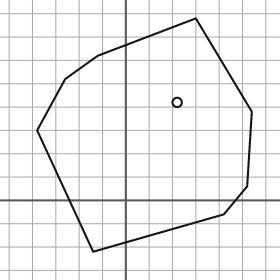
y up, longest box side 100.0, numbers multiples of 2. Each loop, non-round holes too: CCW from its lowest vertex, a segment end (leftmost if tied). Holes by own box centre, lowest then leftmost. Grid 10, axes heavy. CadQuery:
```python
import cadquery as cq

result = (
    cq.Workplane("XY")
    .moveTo(-14.0, -22.0)
    .lineTo(42.0, -6.0)
    .lineTo(52.0, 6.0)
    .lineTo(54.0, 38.0)
    .lineTo(30.0, 78.0)
    .lineTo(-12.0, 62.0)
    .lineTo(-26.0, 52.0)
    .lineTo(-38.0, 30.0)
    .close()
    .moveTo(22.0, 42.0)
    .circle(2.0)
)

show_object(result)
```